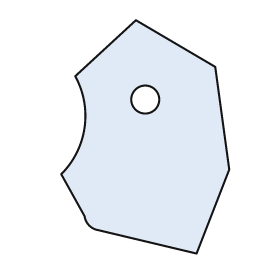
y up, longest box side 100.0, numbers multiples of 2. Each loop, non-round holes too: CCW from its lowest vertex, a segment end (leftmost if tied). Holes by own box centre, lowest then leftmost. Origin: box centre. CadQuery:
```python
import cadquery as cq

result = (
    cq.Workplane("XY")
    .moveTo(22.0, -50.0)
    .lineTo(36.0, -14.0)
    .lineTo(30.0, 30.0)
    .lineTo(-4.0, 50.0)
    .lineTo(-30.0, 26.0)
    .threePointArc((-26.0, 4.0), (-36.0, -16.0))
    .lineTo(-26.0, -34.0)
    .threePointArc((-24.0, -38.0), (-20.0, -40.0))
    .close()
    .moveTo(0.0, 16.0)
    .circle(6.0)
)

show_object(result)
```